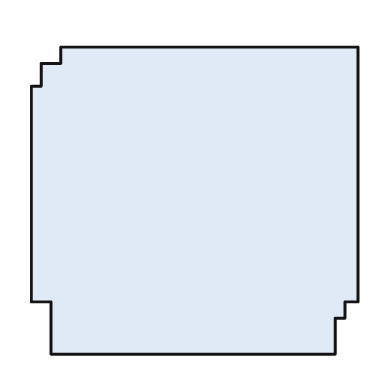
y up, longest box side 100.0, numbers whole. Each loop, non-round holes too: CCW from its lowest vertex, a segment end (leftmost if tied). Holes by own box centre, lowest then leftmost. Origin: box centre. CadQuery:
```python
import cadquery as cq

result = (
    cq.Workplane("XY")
    .moveTo(-44.0, -47.0)
    .lineTo(43.0, -47.0)
    .lineTo(43.0, -36.0)
    .lineTo(46.0, -36.0)
    .lineTo(46.0, -31.0)
    .lineTo(50.0, -31.0)
    .lineTo(50.0, 47.0)
    .lineTo(-41.0, 47.0)
    .lineTo(-41.0, 42.0)
    .lineTo(-47.0, 42.0)
    .lineTo(-47.0, 35.0)
    .lineTo(-50.0, 35.0)
    .lineTo(-50.0, -31.0)
    .lineTo(-44.0, -31.0)
    .close()
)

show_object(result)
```